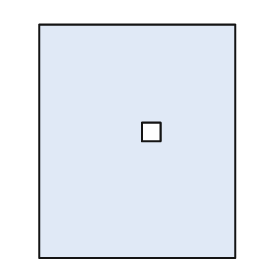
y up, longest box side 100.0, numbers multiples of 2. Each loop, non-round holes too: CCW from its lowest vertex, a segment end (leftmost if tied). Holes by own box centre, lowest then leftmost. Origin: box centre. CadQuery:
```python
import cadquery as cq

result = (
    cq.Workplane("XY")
    .moveTo(-42.0, -50.0)
    .lineTo(42.0, -50.0)
    .lineTo(42.0, 50.0)
    .lineTo(-42.0, 50.0)
    .close()
    .moveTo(2.0, 0.0)
    .lineTo(10.0, 0.0)
    .lineTo(10.0, 8.0)
    .lineTo(2.0, 8.0)
    .close()
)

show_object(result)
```